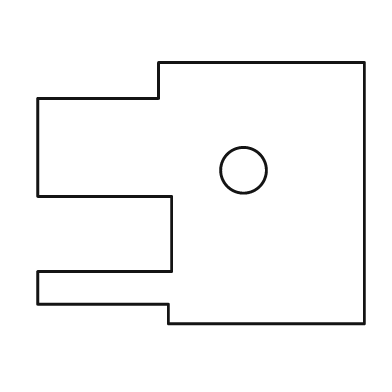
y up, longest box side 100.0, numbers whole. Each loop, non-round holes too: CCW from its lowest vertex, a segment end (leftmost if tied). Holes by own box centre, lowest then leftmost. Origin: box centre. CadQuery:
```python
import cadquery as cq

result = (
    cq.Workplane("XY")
    .moveTo(-10.0, -40.0)
    .lineTo(50.0, -40.0)
    .lineTo(50.0, 40.0)
    .lineTo(-13.0, 40.0)
    .lineTo(-13.0, 29.0)
    .lineTo(-50.0, 29.0)
    .lineTo(-50.0, -1.0)
    .lineTo(-9.0, -1.0)
    .lineTo(-9.0, -24.0)
    .lineTo(-50.0, -24.0)
    .lineTo(-50.0, -34.0)
    .lineTo(-10.0, -34.0)
    .close()
    .moveTo(13.0, 7.0)
    .circle(7.0)
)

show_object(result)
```